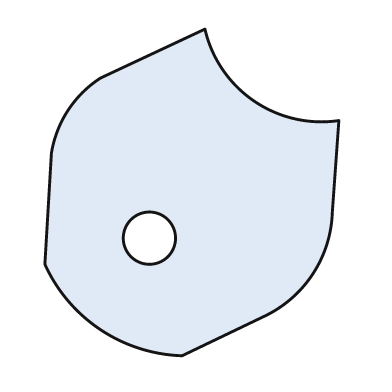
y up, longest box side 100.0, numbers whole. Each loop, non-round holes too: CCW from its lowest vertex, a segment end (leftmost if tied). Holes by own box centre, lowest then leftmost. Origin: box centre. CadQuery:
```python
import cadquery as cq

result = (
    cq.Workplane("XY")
    .moveTo(-3.0, -50.0)
    .lineTo(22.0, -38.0)
    .threePointArc((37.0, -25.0), (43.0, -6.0))
    .lineTo(45.0, 22.0)
    .threePointArc((19.0, 28.0), (4.0, 50.0))
    .lineTo(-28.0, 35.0)
    .threePointArc((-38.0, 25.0), (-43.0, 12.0))
    .lineTo(-45.0, -22.0)
    .threePointArc((-28.0, -42.0), (-3.0, -50.0))
    .close()
    .moveTo(-13.0, -14.0)
    .circle(8.0)
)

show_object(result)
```